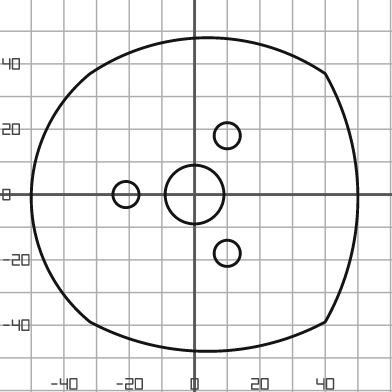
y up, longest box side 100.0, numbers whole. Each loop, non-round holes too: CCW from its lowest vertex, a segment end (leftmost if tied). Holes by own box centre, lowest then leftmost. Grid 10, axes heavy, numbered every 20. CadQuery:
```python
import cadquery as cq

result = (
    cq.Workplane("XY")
    .moveTo(-32.0, -39.0)
    .threePointArc((4.0, -48.0), (40.0, -39.0))
    .threePointArc((50.0, -1.0), (40.0, 37.0))
    .threePointArc((4.0, 48.0), (-32.0, 37.0))
    .threePointArc((-50.0, -1.0), (-32.0, -39.0))
    .close()
    .moveTo(10.0, -18.0)
    .circle(4.0)
    .moveTo(-21.0, 0.0)
    .circle(4.0)
    .moveTo(0.0, 0.0)
    .circle(9.0)
    .moveTo(10.0, 18.0)
    .circle(4.0)
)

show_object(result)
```